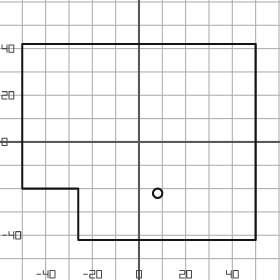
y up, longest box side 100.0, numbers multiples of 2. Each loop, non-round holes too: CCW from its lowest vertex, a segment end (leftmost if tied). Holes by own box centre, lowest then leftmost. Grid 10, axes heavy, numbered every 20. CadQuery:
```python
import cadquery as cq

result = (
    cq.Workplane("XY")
    .moveTo(-26.0, -42.0)
    .lineTo(50.0, -42.0)
    .lineTo(50.0, 42.0)
    .lineTo(-50.0, 42.0)
    .lineTo(-50.0, -20.0)
    .lineTo(-26.0, -20.0)
    .close()
    .moveTo(8.0, -22.0)
    .circle(2.0)
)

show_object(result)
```